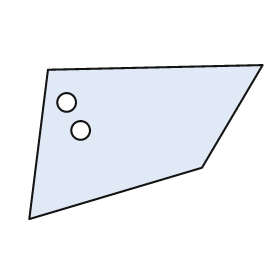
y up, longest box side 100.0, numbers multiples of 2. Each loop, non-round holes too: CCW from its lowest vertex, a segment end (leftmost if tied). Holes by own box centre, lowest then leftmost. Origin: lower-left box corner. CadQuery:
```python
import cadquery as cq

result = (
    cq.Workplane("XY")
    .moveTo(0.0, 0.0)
    .lineTo(74.0, 22.0)
    .lineTo(100.0, 66.0)
    .lineTo(8.0, 64.0)
    .close()
    .moveTo(22.0, 38.0)
    .circle(4.0)
    .moveTo(16.0, 50.0)
    .circle(4.0)
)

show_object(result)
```